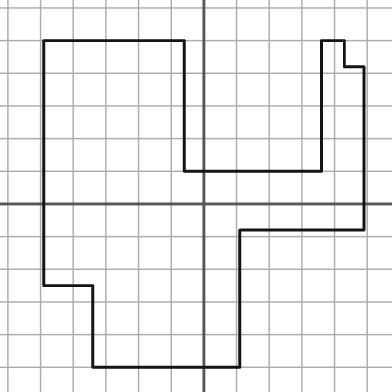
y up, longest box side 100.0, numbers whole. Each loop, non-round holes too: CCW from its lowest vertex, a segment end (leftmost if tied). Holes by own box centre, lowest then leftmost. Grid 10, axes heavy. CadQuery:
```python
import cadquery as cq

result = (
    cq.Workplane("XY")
    .moveTo(-34.0, -50.0)
    .lineTo(11.0, -50.0)
    .lineTo(11.0, -8.0)
    .lineTo(49.0, -8.0)
    .lineTo(49.0, 42.0)
    .lineTo(43.0, 42.0)
    .lineTo(43.0, 50.0)
    .lineTo(36.0, 50.0)
    .lineTo(36.0, 10.0)
    .lineTo(-6.0, 10.0)
    .lineTo(-6.0, 50.0)
    .lineTo(-49.0, 50.0)
    .lineTo(-49.0, -25.0)
    .lineTo(-34.0, -25.0)
    .close()
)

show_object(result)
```